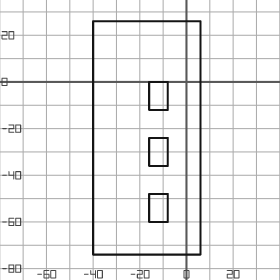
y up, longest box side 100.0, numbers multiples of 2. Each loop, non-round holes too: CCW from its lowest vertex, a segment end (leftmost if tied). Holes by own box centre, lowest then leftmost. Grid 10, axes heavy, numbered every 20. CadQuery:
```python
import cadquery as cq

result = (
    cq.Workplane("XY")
    .moveTo(-40.0, -74.0)
    .lineTo(6.0, -74.0)
    .lineTo(6.0, 26.0)
    .lineTo(-40.0, 26.0)
    .close()
    .moveTo(-16.0, -60.0)
    .lineTo(-8.0, -60.0)
    .lineTo(-8.0, -48.0)
    .lineTo(-16.0, -48.0)
    .close()
    .moveTo(-16.0, -36.0)
    .lineTo(-8.0, -36.0)
    .lineTo(-8.0, -24.0)
    .lineTo(-16.0, -24.0)
    .close()
    .moveTo(-16.0, -12.0)
    .lineTo(-8.0, -12.0)
    .lineTo(-8.0, 0.0)
    .lineTo(-16.0, 0.0)
    .close()
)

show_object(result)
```